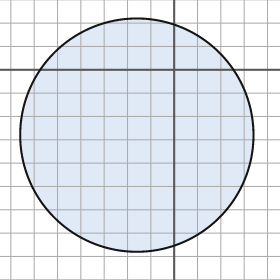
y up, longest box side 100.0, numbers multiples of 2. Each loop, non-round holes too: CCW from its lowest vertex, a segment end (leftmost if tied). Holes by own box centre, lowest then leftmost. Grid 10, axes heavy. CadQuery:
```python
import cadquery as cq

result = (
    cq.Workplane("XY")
    .moveTo(-16.0, -28.0)
    .circle(50.0)
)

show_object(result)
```